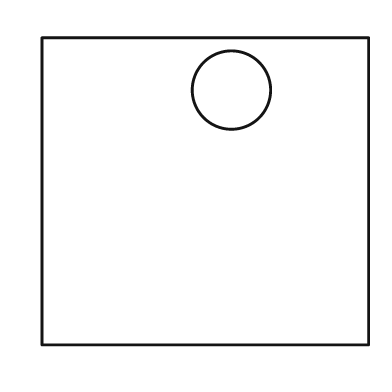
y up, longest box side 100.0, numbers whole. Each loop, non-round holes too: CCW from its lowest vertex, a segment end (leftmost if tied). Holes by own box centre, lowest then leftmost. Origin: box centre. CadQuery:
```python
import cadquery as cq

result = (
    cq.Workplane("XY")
    .moveTo(-50.0, -47.0)
    .lineTo(50.0, -47.0)
    .lineTo(50.0, 47.0)
    .lineTo(-50.0, 47.0)
    .close()
    .moveTo(8.0, 31.0)
    .circle(12.0)
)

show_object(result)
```